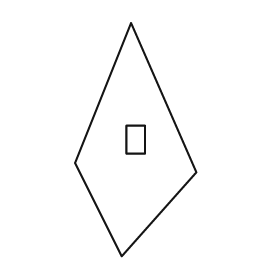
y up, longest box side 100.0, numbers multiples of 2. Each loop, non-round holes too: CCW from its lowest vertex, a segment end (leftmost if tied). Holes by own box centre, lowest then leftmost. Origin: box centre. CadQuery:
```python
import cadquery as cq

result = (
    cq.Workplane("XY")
    .moveTo(-6.0, -50.0)
    .lineTo(26.0, -14.0)
    .lineTo(-2.0, 50.0)
    .lineTo(-26.0, -10.0)
    .close()
    .moveTo(-4.0, -6.0)
    .lineTo(4.0, -6.0)
    .lineTo(4.0, 6.0)
    .lineTo(-4.0, 6.0)
    .close()
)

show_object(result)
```